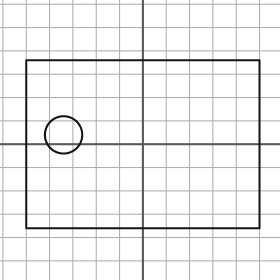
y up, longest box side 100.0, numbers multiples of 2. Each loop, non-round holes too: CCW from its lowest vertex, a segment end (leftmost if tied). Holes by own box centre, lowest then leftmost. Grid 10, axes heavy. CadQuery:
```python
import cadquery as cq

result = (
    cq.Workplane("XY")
    .moveTo(-50.0, -36.0)
    .lineTo(50.0, -36.0)
    .lineTo(50.0, 36.0)
    .lineTo(-50.0, 36.0)
    .close()
    .moveTo(-34.0, 4.0)
    .circle(8.0)
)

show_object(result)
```